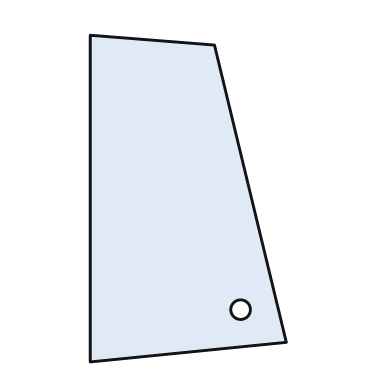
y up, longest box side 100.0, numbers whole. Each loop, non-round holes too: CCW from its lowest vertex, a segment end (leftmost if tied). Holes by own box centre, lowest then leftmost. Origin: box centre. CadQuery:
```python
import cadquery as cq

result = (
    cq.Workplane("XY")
    .moveTo(-30.0, -50.0)
    .lineTo(30.0, -44.0)
    .lineTo(8.0, 47.0)
    .lineTo(-30.0, 50.0)
    .close()
    .moveTo(16.0, -34.0)
    .circle(3.0)
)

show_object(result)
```